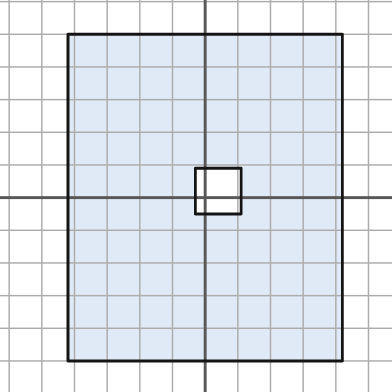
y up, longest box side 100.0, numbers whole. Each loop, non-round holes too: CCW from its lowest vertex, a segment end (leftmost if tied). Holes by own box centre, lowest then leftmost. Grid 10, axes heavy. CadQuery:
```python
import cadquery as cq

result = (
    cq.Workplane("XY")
    .moveTo(-42.0, -50.0)
    .lineTo(42.0, -50.0)
    .lineTo(42.0, 50.0)
    .lineTo(-42.0, 50.0)
    .close()
    .moveTo(-3.0, -5.0)
    .lineTo(11.0, -5.0)
    .lineTo(11.0, 9.0)
    .lineTo(-3.0, 9.0)
    .close()
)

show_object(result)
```